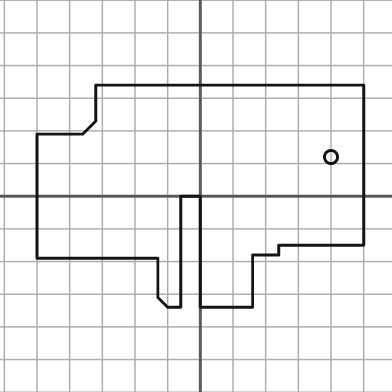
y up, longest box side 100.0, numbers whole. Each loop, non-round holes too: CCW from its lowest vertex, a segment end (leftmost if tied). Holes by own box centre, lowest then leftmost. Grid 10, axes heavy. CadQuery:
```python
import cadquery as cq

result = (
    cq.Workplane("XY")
    .moveTo(-10.0, -34.0)
    .lineTo(-6.0, -34.0)
    .lineTo(-6.0, 0.0)
    .lineTo(0.0, 0.0)
    .lineTo(0.0, -34.0)
    .lineTo(16.0, -34.0)
    .lineTo(16.0, -18.0)
    .lineTo(24.0, -18.0)
    .lineTo(24.0, -15.0)
    .lineTo(50.0, -15.0)
    .lineTo(50.0, 34.0)
    .lineTo(-32.0, 34.0)
    .lineTo(-32.0, 23.0)
    .lineTo(-36.0, 19.0)
    .lineTo(-50.0, 19.0)
    .lineTo(-50.0, -19.0)
    .lineTo(-13.0, -19.0)
    .lineTo(-13.0, -31.0)
    .close()
    .moveTo(40.0, 12.0)
    .circle(2.0)
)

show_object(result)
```